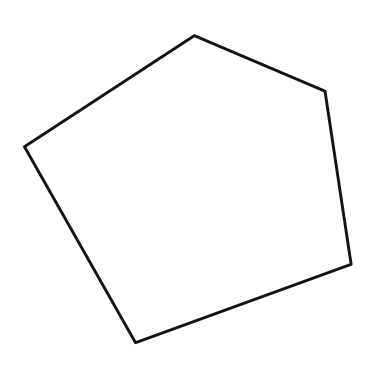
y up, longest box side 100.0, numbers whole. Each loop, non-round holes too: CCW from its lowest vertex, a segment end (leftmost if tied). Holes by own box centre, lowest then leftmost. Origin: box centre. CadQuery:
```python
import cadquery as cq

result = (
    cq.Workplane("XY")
    .moveTo(-16.0, -47.0)
    .lineTo(50.0, -23.0)
    .lineTo(42.0, 30.0)
    .lineTo(2.0, 47.0)
    .lineTo(-50.0, 13.0)
    .close()
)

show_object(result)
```